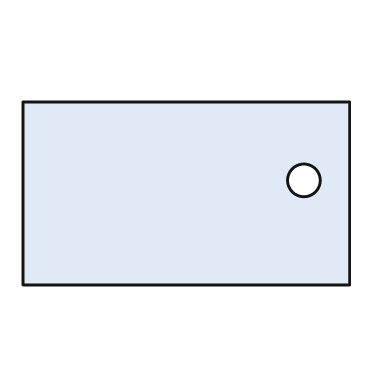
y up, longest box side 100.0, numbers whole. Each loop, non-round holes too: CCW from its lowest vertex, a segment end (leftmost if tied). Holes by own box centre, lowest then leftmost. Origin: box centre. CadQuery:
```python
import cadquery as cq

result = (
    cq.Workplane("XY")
    .moveTo(-50.0, -28.0)
    .lineTo(50.0, -28.0)
    .lineTo(50.0, 28.0)
    .lineTo(-50.0, 28.0)
    .close()
    .moveTo(36.0, 4.0)
    .circle(5.0)
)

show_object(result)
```